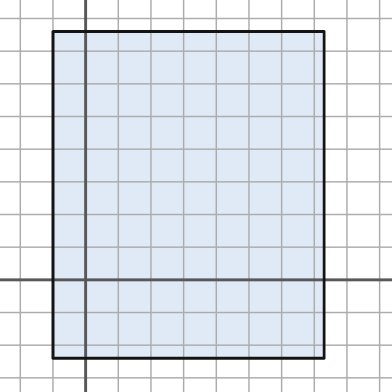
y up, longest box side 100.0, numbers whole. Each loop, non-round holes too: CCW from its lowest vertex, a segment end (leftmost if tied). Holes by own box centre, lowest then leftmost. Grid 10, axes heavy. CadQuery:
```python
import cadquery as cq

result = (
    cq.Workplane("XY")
    .moveTo(-10.0, -24.0)
    .lineTo(73.0, -24.0)
    .lineTo(73.0, 76.0)
    .lineTo(-10.0, 76.0)
    .close()
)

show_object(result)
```